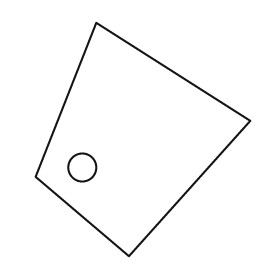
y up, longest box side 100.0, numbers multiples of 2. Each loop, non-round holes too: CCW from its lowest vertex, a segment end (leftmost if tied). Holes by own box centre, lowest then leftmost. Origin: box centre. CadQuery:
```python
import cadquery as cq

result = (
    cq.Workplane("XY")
    .moveTo(-6.0, -50.0)
    .lineTo(46.0, 8.0)
    .lineTo(-20.0, 50.0)
    .lineTo(-46.0, -16.0)
    .close()
    .moveTo(-26.0, -12.0)
    .circle(6.0)
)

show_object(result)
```